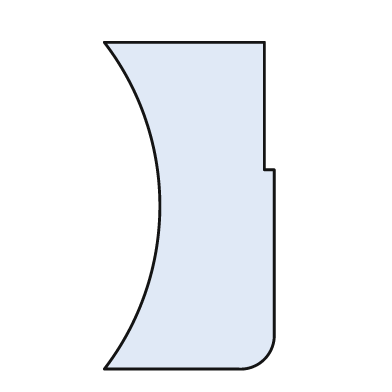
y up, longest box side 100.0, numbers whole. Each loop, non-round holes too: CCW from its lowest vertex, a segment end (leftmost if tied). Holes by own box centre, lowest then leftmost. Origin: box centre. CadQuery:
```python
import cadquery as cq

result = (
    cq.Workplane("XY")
    .moveTo(-26.0, -50.0)
    .lineTo(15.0, -50.0)
    .threePointArc((23.0, -47.0), (26.0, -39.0))
    .lineTo(26.0, 11.0)
    .lineTo(23.0, 11.0)
    .lineTo(23.0, 50.0)
    .lineTo(-26.0, 50.0)
    .threePointArc((-9.0, 0.0), (-26.0, -50.0))
    .close()
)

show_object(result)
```